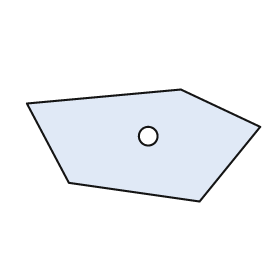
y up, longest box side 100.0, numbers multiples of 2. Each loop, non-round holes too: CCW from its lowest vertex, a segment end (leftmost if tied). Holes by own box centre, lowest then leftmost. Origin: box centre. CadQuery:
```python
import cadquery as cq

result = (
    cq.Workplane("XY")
    .moveTo(24.0, -24.0)
    .lineTo(50.0, 8.0)
    .lineTo(16.0, 24.0)
    .lineTo(-50.0, 18.0)
    .lineTo(-32.0, -16.0)
    .close()
    .moveTo(2.0, 4.0)
    .circle(4.0)
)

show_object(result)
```